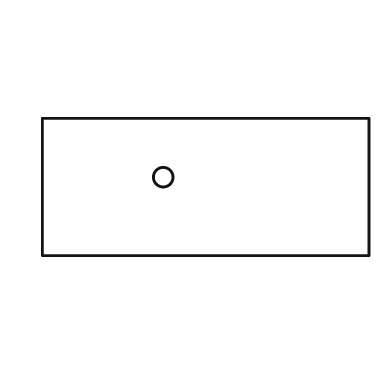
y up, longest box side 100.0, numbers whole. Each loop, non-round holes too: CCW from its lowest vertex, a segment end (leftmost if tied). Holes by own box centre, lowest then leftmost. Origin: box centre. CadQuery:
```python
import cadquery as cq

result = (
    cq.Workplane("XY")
    .moveTo(-50.0, -21.0)
    .lineTo(50.0, -21.0)
    .lineTo(50.0, 21.0)
    .lineTo(-50.0, 21.0)
    .close()
    .moveTo(-13.0, 3.0)
    .circle(3.0)
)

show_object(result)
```